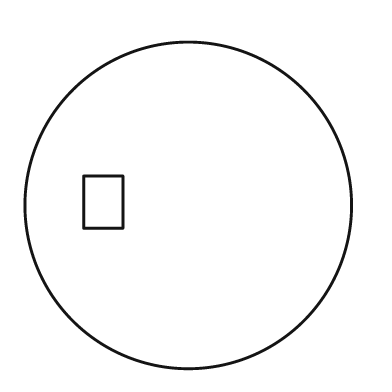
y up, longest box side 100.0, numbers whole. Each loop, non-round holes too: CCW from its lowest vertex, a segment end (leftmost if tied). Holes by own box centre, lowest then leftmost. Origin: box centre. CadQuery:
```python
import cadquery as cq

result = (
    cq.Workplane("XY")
    .moveTo(0.0, 0.0)
    .circle(50.0)
    .moveTo(-32.0, -7.0)
    .lineTo(-20.0, -7.0)
    .lineTo(-20.0, 9.0)
    .lineTo(-32.0, 9.0)
    .close()
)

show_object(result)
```